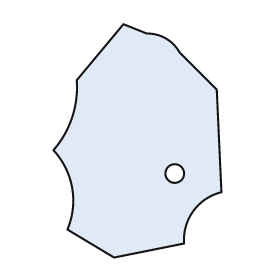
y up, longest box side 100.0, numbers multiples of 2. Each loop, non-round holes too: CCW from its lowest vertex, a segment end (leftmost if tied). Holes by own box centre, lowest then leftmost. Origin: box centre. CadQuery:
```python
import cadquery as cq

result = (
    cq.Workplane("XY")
    .moveTo(-10.0, -50.0)
    .lineTo(20.0, -44.0)
    .threePointArc((24.0, -30.0), (36.0, -22.0))
    .lineTo(34.0, 22.0)
    .lineTo(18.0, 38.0)
    .threePointArc((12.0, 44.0), (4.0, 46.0))
    .lineTo(-6.0, 50.0)
    .lineTo(-26.0, 26.0)
    .threePointArc((-28.0, 10.0), (-36.0, -4.0))
    .threePointArc((-28.0, -20.0), (-30.0, -38.0))
    .close()
    .moveTo(16.0, -14.0)
    .circle(4.0)
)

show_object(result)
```